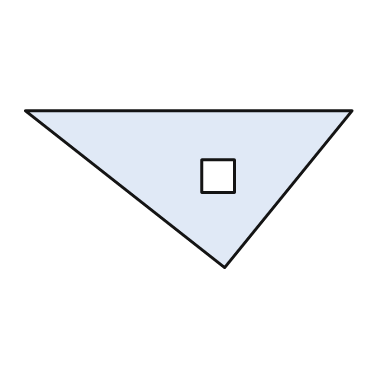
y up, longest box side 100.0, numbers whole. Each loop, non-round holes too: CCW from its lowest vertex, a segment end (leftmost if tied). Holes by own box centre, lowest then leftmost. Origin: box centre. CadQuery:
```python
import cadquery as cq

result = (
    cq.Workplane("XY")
    .moveTo(11.0, -24.0)
    .lineTo(50.0, 24.0)
    .lineTo(-50.0, 24.0)
    .close()
    .moveTo(4.0, -1.0)
    .lineTo(14.0, -1.0)
    .lineTo(14.0, 9.0)
    .lineTo(4.0, 9.0)
    .close()
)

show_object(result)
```